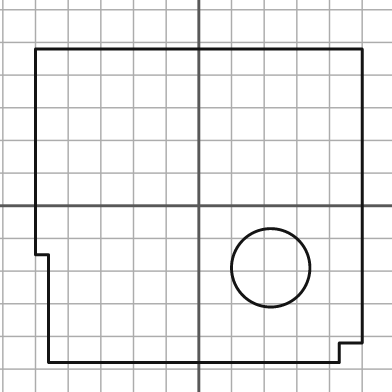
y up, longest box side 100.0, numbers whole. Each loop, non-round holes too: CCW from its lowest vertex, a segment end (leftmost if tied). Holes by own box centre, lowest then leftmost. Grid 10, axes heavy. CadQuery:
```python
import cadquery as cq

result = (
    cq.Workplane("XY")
    .moveTo(-46.0, -48.0)
    .lineTo(43.0, -48.0)
    .lineTo(43.0, -42.0)
    .lineTo(50.0, -42.0)
    .lineTo(50.0, 48.0)
    .lineTo(-50.0, 48.0)
    .lineTo(-50.0, -15.0)
    .lineTo(-46.0, -15.0)
    .close()
    .moveTo(22.0, -19.0)
    .circle(12.0)
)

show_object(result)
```